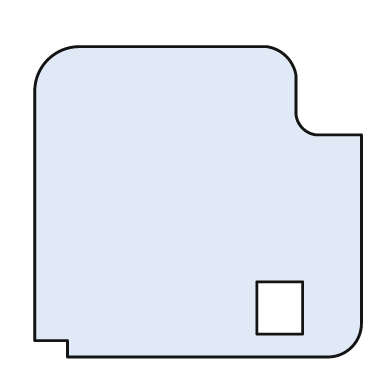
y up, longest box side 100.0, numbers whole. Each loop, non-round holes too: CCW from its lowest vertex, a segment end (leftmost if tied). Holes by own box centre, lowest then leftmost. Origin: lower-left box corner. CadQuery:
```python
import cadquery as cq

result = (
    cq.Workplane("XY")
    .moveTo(10.0, 0.0)
    .lineTo(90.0, 0.0)
    .threePointArc((97.0, 3.0), (100.0, 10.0))
    .lineTo(100.0, 68.0)
    .lineTo(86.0, 68.0)
    .threePointArc((82.0, 70.0), (80.0, 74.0))
    .lineTo(80.0, 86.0)
    .threePointArc((77.0, 92.0), (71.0, 95.0))
    .lineTo(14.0, 95.0)
    .threePointArc((4.0, 91.0), (0.0, 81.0))
    .lineTo(0.0, 5.0)
    .lineTo(10.0, 5.0)
    .close()
    .moveTo(68.0, 7.0)
    .lineTo(82.0, 7.0)
    .lineTo(82.0, 23.0)
    .lineTo(68.0, 23.0)
    .close()
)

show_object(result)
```